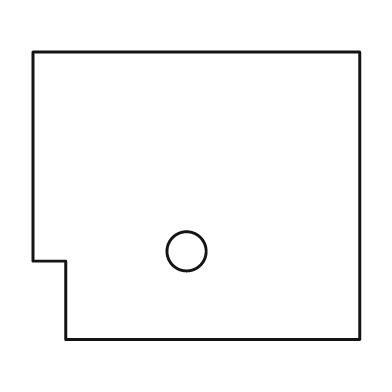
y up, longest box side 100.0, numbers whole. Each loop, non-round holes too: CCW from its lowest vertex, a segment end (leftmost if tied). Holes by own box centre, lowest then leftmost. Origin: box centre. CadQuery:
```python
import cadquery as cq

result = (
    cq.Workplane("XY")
    .moveTo(-40.0, -44.0)
    .lineTo(50.0, -44.0)
    .lineTo(50.0, 44.0)
    .lineTo(-50.0, 44.0)
    .lineTo(-50.0, -20.0)
    .lineTo(-40.0, -20.0)
    .close()
    .moveTo(-3.0, -17.0)
    .circle(6.0)
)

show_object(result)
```